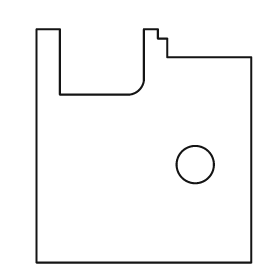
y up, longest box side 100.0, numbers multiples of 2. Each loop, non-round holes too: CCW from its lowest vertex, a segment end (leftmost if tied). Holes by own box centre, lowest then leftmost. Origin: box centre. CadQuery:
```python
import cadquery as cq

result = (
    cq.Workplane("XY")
    .moveTo(-46.0, -50.0)
    .lineTo(46.0, -50.0)
    .lineTo(46.0, 38.0)
    .lineTo(10.0, 38.0)
    .lineTo(10.0, 46.0)
    .lineTo(6.0, 46.0)
    .lineTo(6.0, 50.0)
    .lineTo(0.0, 50.0)
    .lineTo(0.0, 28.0)
    .threePointArc((-2.0, 24.0), (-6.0, 22.0))
    .lineTo(-36.0, 22.0)
    .lineTo(-36.0, 50.0)
    .lineTo(-46.0, 50.0)
    .close()
    .moveTo(22.0, -8.0)
    .circle(8.0)
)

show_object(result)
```